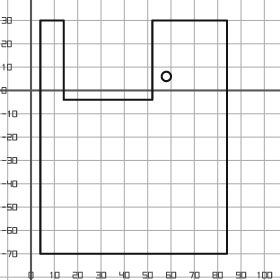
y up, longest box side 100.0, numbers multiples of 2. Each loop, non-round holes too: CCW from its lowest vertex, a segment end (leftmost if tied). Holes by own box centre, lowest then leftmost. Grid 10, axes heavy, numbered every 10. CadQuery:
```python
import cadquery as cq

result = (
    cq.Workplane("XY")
    .moveTo(4.0, -70.0)
    .lineTo(84.0, -70.0)
    .lineTo(84.0, 30.0)
    .lineTo(52.0, 30.0)
    .lineTo(52.0, -4.0)
    .lineTo(14.0, -4.0)
    .lineTo(14.0, 30.0)
    .lineTo(4.0, 30.0)
    .close()
    .moveTo(58.0, 6.0)
    .circle(2.0)
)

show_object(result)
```